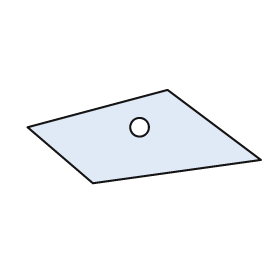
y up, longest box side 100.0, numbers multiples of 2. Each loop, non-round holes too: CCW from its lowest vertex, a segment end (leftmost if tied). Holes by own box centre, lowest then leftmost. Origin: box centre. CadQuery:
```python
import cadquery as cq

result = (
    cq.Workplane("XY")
    .moveTo(-22.0, -20.0)
    .lineTo(50.0, -10.0)
    .lineTo(10.0, 20.0)
    .lineTo(-50.0, 4.0)
    .close()
    .moveTo(-2.0, 4.0)
    .circle(4.0)
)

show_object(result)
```